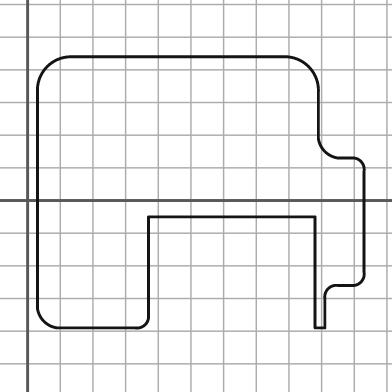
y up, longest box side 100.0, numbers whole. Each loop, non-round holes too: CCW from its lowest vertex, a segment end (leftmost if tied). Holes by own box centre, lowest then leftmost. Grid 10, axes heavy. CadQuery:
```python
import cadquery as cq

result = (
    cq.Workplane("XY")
    .moveTo(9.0, -39.0)
    .lineTo(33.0, -39.0)
    .threePointArc((36.0, -38.0), (37.0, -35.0))
    .lineTo(37.0, -5.0)
    .lineTo(88.0, -5.0)
    .lineTo(88.0, -39.0)
    .lineTo(91.0, -39.0)
    .lineTo(91.0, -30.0)
    .threePointArc((92.0, -27.0), (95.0, -26.0))
    .lineTo(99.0, -26.0)
    .threePointArc((102.0, -25.0), (103.0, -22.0))
    .lineTo(103.0, 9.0)
    .threePointArc((102.0, 12.0), (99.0, 13.0))
    .lineTo(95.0, 13.0)
    .threePointArc((91.0, 15.0), (89.0, 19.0))
    .lineTo(89.0, 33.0)
    .threePointArc((86.0, 41.0), (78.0, 44.0))
    .lineTo(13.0, 44.0)
    .threePointArc((6.0, 41.0), (3.0, 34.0))
    .lineTo(3.0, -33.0)
    .threePointArc((5.0, -37.0), (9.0, -39.0))
    .close()
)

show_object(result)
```